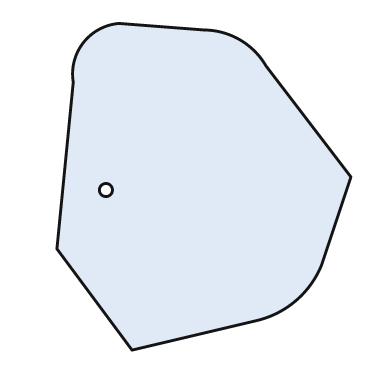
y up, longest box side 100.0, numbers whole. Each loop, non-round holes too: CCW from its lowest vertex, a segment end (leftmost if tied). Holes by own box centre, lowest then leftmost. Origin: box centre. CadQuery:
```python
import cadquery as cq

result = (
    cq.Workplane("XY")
    .moveTo(-22.0, -50.0)
    .lineTo(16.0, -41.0)
    .threePointArc((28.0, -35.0), (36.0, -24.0))
    .lineTo(45.0, 3.0)
    .lineTo(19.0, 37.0)
    .threePointArc((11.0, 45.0), (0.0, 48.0))
    .lineTo(-26.0, 50.0)
    .threePointArc((-37.0, 44.0), (-40.0, 32.0))
    .lineTo(-45.0, -19.0)
    .close()
    .moveTo(-30.0, -1.0)
    .circle(2.0)
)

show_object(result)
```